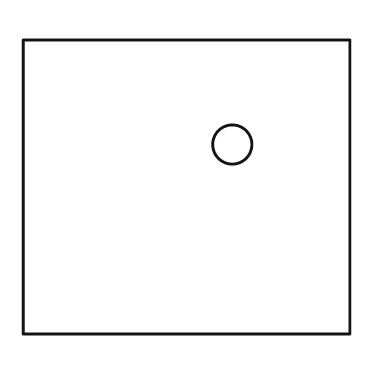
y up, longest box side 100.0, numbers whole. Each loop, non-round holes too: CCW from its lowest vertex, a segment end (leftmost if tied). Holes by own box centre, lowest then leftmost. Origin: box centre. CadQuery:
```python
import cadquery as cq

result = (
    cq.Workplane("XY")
    .moveTo(-50.0, -45.0)
    .lineTo(50.0, -45.0)
    .lineTo(50.0, 45.0)
    .lineTo(-50.0, 45.0)
    .close()
    .moveTo(14.0, 13.0)
    .circle(6.0)
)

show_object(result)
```